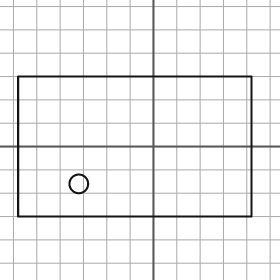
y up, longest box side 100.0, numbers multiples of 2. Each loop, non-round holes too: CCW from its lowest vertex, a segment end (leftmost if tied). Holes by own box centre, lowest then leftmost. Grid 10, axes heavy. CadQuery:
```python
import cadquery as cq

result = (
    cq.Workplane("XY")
    .moveTo(-58.0, -30.0)
    .lineTo(42.0, -30.0)
    .lineTo(42.0, 30.0)
    .lineTo(-58.0, 30.0)
    .close()
    .moveTo(-32.0, -16.0)
    .circle(4.0)
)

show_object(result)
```